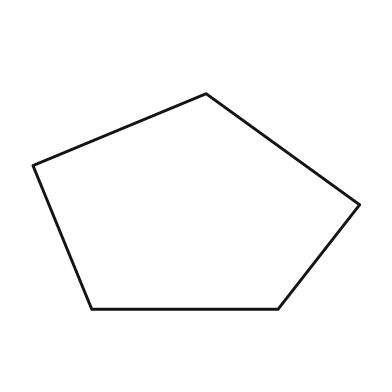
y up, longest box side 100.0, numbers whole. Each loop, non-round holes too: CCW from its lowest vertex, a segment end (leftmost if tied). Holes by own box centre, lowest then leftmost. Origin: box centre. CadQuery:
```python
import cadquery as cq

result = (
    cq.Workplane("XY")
    .moveTo(-32.0, -33.0)
    .lineTo(25.0, -33.0)
    .lineTo(50.0, -1.0)
    .lineTo(3.0, 33.0)
    .lineTo(-50.0, 11.0)
    .close()
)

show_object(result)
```